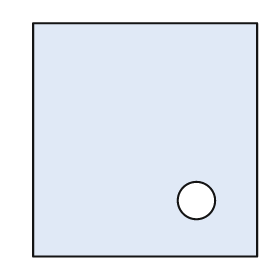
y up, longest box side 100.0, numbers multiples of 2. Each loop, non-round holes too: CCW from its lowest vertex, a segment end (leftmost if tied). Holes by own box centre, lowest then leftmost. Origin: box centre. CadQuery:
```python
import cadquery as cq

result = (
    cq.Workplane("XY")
    .moveTo(-48.0, -50.0)
    .lineTo(48.0, -50.0)
    .lineTo(48.0, 50.0)
    .lineTo(-48.0, 50.0)
    .close()
    .moveTo(22.0, -26.0)
    .circle(8.0)
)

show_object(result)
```